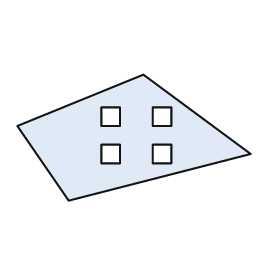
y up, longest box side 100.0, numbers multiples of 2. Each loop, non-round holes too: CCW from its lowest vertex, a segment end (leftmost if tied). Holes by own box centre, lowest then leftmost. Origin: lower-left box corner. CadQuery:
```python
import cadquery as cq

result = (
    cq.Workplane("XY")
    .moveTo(22.0, 0.0)
    .lineTo(100.0, 20.0)
    .lineTo(54.0, 54.0)
    .lineTo(0.0, 32.0)
    .close()
    .moveTo(36.0, 16.0)
    .lineTo(44.0, 16.0)
    .lineTo(44.0, 24.0)
    .lineTo(36.0, 24.0)
    .close()
    .moveTo(58.0, 16.0)
    .lineTo(66.0, 16.0)
    .lineTo(66.0, 24.0)
    .lineTo(58.0, 24.0)
    .close()
    .moveTo(36.0, 32.0)
    .lineTo(44.0, 32.0)
    .lineTo(44.0, 40.0)
    .lineTo(36.0, 40.0)
    .close()
    .moveTo(58.0, 32.0)
    .lineTo(66.0, 32.0)
    .lineTo(66.0, 40.0)
    .lineTo(58.0, 40.0)
    .close()
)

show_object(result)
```